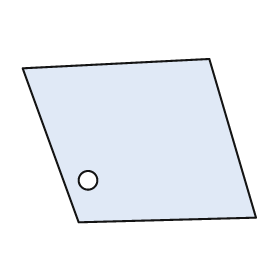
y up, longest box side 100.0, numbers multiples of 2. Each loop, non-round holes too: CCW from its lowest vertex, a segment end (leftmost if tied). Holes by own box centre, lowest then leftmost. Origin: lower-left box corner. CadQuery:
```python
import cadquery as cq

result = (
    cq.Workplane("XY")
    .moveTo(24.0, 0.0)
    .lineTo(100.0, 2.0)
    .lineTo(80.0, 70.0)
    .lineTo(0.0, 66.0)
    .close()
    .moveTo(28.0, 18.0)
    .circle(4.0)
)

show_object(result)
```